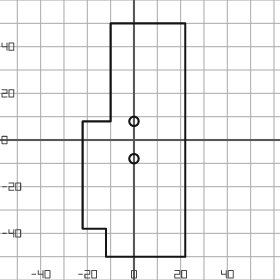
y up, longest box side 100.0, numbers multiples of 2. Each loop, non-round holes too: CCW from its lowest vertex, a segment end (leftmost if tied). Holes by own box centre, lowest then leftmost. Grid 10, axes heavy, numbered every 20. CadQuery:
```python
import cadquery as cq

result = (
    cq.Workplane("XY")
    .moveTo(-12.0, -50.0)
    .lineTo(22.0, -50.0)
    .lineTo(22.0, 50.0)
    .lineTo(-10.0, 50.0)
    .lineTo(-10.0, 8.0)
    .lineTo(-22.0, 8.0)
    .lineTo(-22.0, -38.0)
    .lineTo(-12.0, -38.0)
    .close()
    .moveTo(0.0, -8.0)
    .circle(2.0)
    .moveTo(0.0, 8.0)
    .circle(2.0)
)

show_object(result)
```